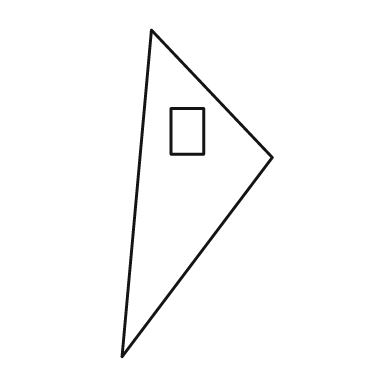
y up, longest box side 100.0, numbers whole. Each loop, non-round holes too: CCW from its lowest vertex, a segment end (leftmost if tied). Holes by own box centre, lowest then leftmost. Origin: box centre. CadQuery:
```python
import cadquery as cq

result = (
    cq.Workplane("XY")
    .moveTo(-23.0, -50.0)
    .lineTo(23.0, 11.0)
    .lineTo(-14.0, 50.0)
    .close()
    .moveTo(-8.0, 12.0)
    .lineTo(2.0, 12.0)
    .lineTo(2.0, 26.0)
    .lineTo(-8.0, 26.0)
    .close()
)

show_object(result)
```